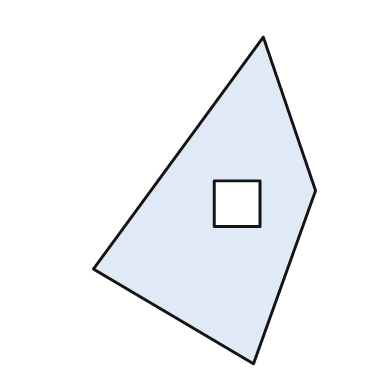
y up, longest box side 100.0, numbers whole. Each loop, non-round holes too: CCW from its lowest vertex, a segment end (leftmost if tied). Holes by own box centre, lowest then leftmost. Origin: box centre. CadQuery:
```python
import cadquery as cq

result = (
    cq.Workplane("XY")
    .moveTo(15.0, -50.0)
    .lineTo(34.0, 3.0)
    .lineTo(18.0, 50.0)
    .lineTo(-34.0, -21.0)
    .close()
    .moveTo(3.0, -8.0)
    .lineTo(17.0, -8.0)
    .lineTo(17.0, 6.0)
    .lineTo(3.0, 6.0)
    .close()
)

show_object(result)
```